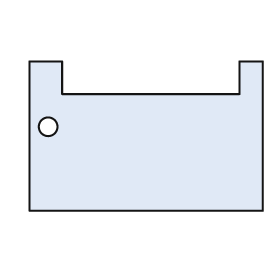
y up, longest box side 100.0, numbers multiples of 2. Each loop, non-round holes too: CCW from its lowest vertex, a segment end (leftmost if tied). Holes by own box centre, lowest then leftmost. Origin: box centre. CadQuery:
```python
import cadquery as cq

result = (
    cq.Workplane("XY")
    .moveTo(-50.0, -32.0)
    .lineTo(50.0, -32.0)
    .lineTo(50.0, 32.0)
    .lineTo(40.0, 32.0)
    .lineTo(40.0, 18.0)
    .lineTo(-36.0, 18.0)
    .lineTo(-36.0, 32.0)
    .lineTo(-50.0, 32.0)
    .close()
    .moveTo(-42.0, 4.0)
    .circle(4.0)
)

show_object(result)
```